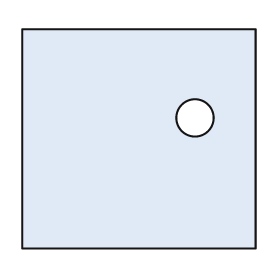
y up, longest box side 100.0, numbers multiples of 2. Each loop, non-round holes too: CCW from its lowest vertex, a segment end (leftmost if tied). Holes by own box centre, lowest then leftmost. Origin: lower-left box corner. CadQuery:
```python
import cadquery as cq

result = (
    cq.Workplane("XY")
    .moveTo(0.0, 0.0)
    .lineTo(100.0, 0.0)
    .lineTo(100.0, 94.0)
    .lineTo(0.0, 94.0)
    .close()
    .moveTo(74.0, 56.0)
    .circle(8.0)
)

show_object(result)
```